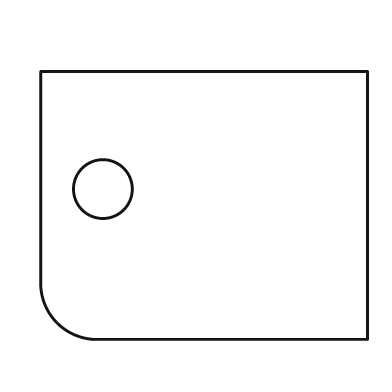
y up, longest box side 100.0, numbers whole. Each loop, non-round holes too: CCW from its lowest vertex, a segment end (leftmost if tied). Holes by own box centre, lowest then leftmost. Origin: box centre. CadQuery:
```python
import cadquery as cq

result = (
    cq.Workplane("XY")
    .moveTo(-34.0, -41.0)
    .lineTo(50.0, -41.0)
    .lineTo(50.0, 41.0)
    .lineTo(-50.0, 41.0)
    .lineTo(-50.0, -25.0)
    .threePointArc((-45.0, -36.0), (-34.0, -41.0))
    .close()
    .moveTo(-31.0, 5.0)
    .circle(9.0)
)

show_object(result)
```